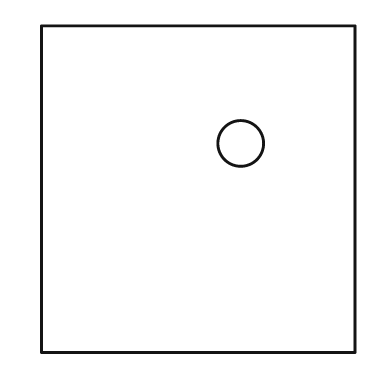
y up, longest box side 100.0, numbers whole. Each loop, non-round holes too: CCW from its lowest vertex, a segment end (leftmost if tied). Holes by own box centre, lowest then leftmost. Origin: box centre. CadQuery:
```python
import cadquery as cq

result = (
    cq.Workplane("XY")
    .moveTo(-48.0, -50.0)
    .lineTo(48.0, -50.0)
    .lineTo(48.0, 50.0)
    .lineTo(-48.0, 50.0)
    .close()
    .moveTo(13.0, 14.0)
    .circle(7.0)
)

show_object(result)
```